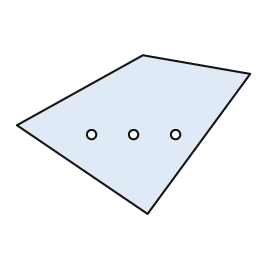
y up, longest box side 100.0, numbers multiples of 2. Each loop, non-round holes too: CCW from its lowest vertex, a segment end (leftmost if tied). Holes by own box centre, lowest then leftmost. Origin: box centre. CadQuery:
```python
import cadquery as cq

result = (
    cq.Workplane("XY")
    .moveTo(6.0, -34.0)
    .lineTo(50.0, 26.0)
    .lineTo(4.0, 34.0)
    .lineTo(-50.0, 4.0)
    .close()
    .moveTo(-18.0, 0.0)
    .circle(2.0)
    .moveTo(0.0, 0.0)
    .circle(2.0)
    .moveTo(18.0, 0.0)
    .circle(2.0)
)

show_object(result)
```